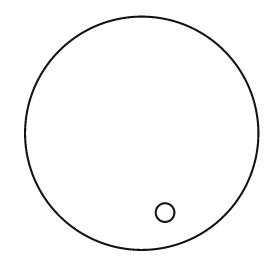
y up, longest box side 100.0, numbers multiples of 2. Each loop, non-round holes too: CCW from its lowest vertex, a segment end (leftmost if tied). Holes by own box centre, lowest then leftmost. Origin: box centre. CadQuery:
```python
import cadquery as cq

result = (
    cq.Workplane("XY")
    .moveTo(0.0, 0.0)
    .circle(50.0)
    .moveTo(10.0, -34.0)
    .circle(4.0)
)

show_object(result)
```